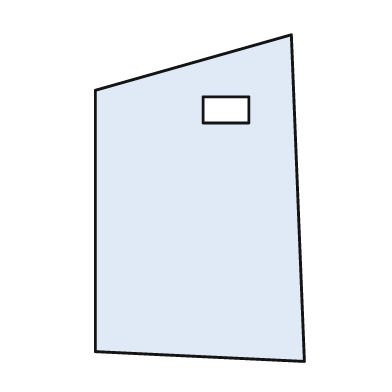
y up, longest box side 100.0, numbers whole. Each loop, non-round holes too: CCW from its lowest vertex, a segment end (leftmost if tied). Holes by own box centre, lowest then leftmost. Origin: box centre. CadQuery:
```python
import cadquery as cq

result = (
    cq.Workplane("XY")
    .moveTo(32.0, -50.0)
    .lineTo(28.0, 50.0)
    .lineTo(-32.0, 33.0)
    .lineTo(-32.0, -47.0)
    .close()
    .moveTo(1.0, 23.0)
    .lineTo(15.0, 23.0)
    .lineTo(15.0, 31.0)
    .lineTo(1.0, 31.0)
    .close()
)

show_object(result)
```